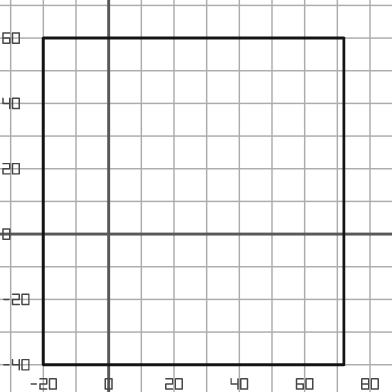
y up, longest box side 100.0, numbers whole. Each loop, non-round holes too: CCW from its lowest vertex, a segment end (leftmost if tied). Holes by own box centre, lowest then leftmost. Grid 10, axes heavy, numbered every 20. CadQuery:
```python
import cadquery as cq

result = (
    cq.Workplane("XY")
    .moveTo(-20.0, -40.0)
    .lineTo(72.0, -40.0)
    .lineTo(72.0, 60.0)
    .lineTo(-20.0, 60.0)
    .close()
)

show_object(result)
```